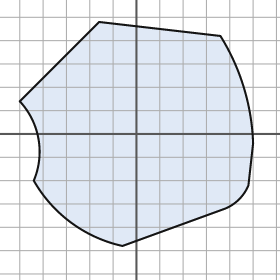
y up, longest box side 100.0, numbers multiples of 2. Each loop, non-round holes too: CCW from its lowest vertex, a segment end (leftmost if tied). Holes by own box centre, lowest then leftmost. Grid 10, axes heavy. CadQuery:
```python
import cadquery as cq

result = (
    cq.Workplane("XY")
    .moveTo(-6.0, -48.0)
    .lineTo(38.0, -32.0)
    .threePointArc((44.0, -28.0), (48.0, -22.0))
    .lineTo(50.0, -4.0)
    .threePointArc((46.0, 20.0), (36.0, 42.0))
    .lineTo(-16.0, 48.0)
    .lineTo(-50.0, 14.0)
    .threePointArc((-42.0, -2.0), (-44.0, -20.0))
    .threePointArc((-28.0, -38.0), (-6.0, -48.0))
    .close()
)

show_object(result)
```